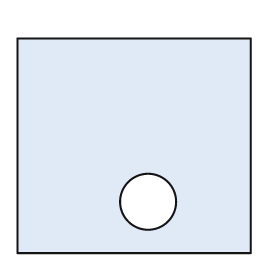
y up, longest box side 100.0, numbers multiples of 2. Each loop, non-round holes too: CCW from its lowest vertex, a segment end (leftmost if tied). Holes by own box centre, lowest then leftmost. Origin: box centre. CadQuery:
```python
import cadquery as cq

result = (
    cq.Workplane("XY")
    .moveTo(-50.0, -46.0)
    .lineTo(50.0, -46.0)
    .lineTo(50.0, 46.0)
    .lineTo(-50.0, 46.0)
    .close()
    .moveTo(6.0, -24.0)
    .circle(12.0)
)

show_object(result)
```